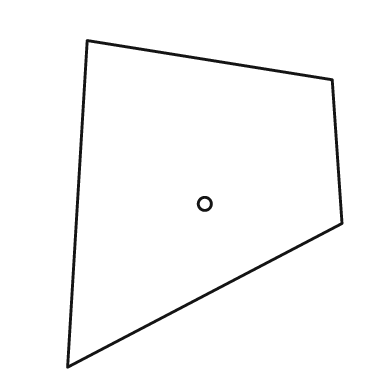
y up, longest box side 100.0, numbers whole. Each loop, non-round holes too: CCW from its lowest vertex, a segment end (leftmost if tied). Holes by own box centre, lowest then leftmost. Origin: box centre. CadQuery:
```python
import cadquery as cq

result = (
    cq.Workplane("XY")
    .moveTo(-42.0, -50.0)
    .lineTo(42.0, -6.0)
    .lineTo(39.0, 38.0)
    .lineTo(-36.0, 50.0)
    .close()
    .moveTo(0.0, 0.0)
    .circle(2.0)
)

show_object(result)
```